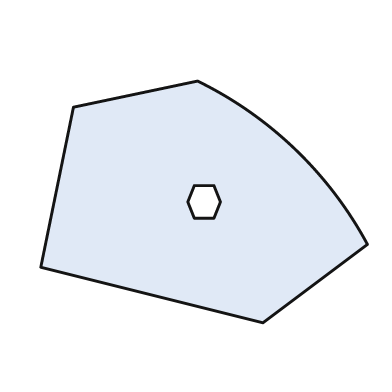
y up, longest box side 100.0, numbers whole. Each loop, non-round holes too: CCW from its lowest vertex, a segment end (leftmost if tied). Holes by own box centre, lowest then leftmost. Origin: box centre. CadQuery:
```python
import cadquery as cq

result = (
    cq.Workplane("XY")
    .moveTo(18.0, -37.0)
    .lineTo(50.0, -13.0)
    .threePointArc((28.0, 16.0), (-2.0, 37.0))
    .lineTo(-40.0, 29.0)
    .lineTo(-50.0, -20.0)
    .close()
    .moveTo(-3.0, -5.0)
    .lineTo(3.0, -5.0)
    .lineTo(5.0, 0.0)
    .lineTo(3.0, 5.0)
    .lineTo(-3.0, 5.0)
    .lineTo(-5.0, 0.0)
    .close()
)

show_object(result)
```